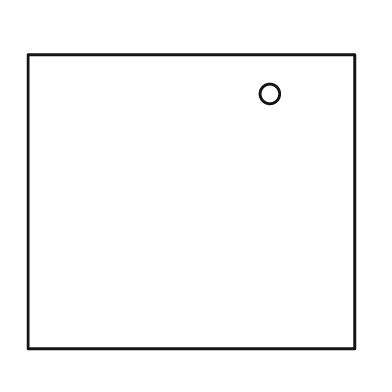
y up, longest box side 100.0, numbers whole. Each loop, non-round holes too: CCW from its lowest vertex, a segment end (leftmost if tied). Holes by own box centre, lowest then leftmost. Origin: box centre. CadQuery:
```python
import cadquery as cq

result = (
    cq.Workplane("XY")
    .moveTo(-50.0, -45.0)
    .lineTo(50.0, -45.0)
    .lineTo(50.0, 45.0)
    .lineTo(-50.0, 45.0)
    .close()
    .moveTo(24.0, 33.0)
    .circle(3.0)
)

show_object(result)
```